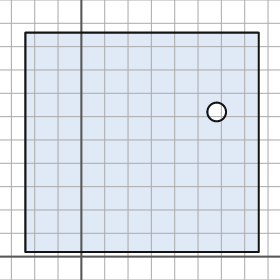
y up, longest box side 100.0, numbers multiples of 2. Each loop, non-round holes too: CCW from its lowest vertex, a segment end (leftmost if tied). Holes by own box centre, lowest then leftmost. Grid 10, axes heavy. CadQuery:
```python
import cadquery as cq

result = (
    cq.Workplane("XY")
    .moveTo(-24.0, 2.0)
    .lineTo(76.0, 2.0)
    .lineTo(76.0, 96.0)
    .lineTo(-24.0, 96.0)
    .close()
    .moveTo(58.0, 62.0)
    .circle(4.0)
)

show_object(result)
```